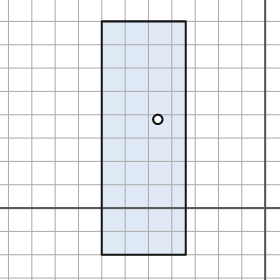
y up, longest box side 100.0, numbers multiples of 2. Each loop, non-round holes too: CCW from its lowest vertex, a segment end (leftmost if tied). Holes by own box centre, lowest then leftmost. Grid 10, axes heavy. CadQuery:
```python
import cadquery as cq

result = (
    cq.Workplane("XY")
    .moveTo(-70.0, -20.0)
    .lineTo(-34.0, -20.0)
    .lineTo(-34.0, 80.0)
    .lineTo(-70.0, 80.0)
    .close()
    .moveTo(-46.0, 38.0)
    .circle(2.0)
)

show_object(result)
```